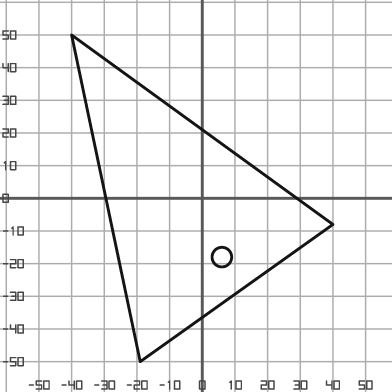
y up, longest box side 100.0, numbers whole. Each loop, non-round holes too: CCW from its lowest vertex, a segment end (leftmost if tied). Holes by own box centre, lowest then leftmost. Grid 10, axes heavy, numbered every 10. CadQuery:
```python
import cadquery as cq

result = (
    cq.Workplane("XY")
    .moveTo(-19.0, -50.0)
    .lineTo(40.0, -8.0)
    .lineTo(-40.0, 50.0)
    .close()
    .moveTo(6.0, -18.0)
    .circle(3.0)
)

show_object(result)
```